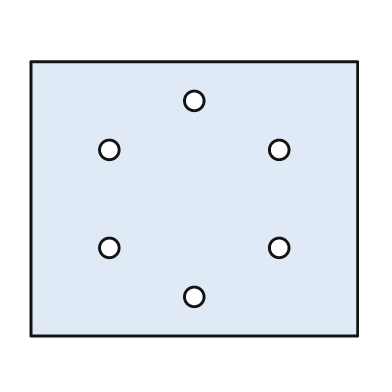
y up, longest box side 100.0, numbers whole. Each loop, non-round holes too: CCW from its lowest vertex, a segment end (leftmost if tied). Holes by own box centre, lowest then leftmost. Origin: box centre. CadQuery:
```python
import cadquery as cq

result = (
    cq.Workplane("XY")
    .moveTo(-50.0, -42.0)
    .lineTo(50.0, -42.0)
    .lineTo(50.0, 42.0)
    .lineTo(-50.0, 42.0)
    .close()
    .moveTo(0.0, -30.0)
    .circle(3.0)
    .moveTo(-26.0, -15.0)
    .circle(3.0)
    .moveTo(26.0, -15.0)
    .circle(3.0)
    .moveTo(-26.0, 15.0)
    .circle(3.0)
    .moveTo(26.0, 15.0)
    .circle(3.0)
    .moveTo(0.0, 30.0)
    .circle(3.0)
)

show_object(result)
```